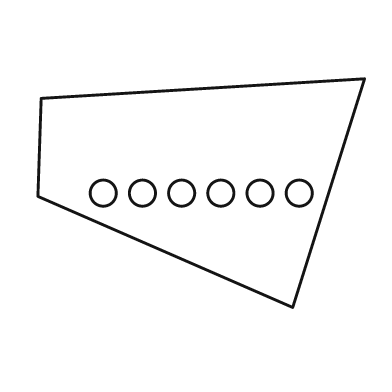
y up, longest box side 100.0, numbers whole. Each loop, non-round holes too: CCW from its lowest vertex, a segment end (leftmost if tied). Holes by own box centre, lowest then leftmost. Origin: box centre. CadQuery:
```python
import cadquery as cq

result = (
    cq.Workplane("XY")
    .moveTo(28.0, -35.0)
    .lineTo(50.0, 35.0)
    .lineTo(-49.0, 29.0)
    .lineTo(-50.0, -1.0)
    .close()
    .moveTo(-30.0, 0.0)
    .circle(4.0)
    .moveTo(-18.0, 0.0)
    .circle(4.0)
    .moveTo(-6.0, 0.0)
    .circle(4.0)
    .moveTo(6.0, 0.0)
    .circle(4.0)
    .moveTo(18.0, 0.0)
    .circle(4.0)
    .moveTo(30.0, 0.0)
    .circle(4.0)
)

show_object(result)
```